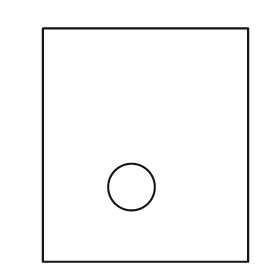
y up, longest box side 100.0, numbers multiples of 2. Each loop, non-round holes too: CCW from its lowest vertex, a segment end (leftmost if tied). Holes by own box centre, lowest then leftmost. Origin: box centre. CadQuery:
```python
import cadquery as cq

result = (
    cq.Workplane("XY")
    .moveTo(-44.0, -50.0)
    .lineTo(44.0, -50.0)
    .lineTo(44.0, 50.0)
    .lineTo(-44.0, 50.0)
    .close()
    .moveTo(-6.0, -18.0)
    .circle(10.0)
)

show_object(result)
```